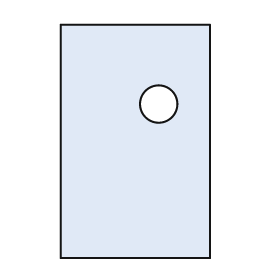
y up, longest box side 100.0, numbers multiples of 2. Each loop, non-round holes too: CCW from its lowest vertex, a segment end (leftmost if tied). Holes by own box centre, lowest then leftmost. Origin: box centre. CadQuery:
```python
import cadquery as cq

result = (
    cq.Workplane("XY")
    .moveTo(-32.0, -50.0)
    .lineTo(32.0, -50.0)
    .lineTo(32.0, 50.0)
    .lineTo(-32.0, 50.0)
    .close()
    .moveTo(10.0, 16.0)
    .circle(8.0)
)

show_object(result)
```